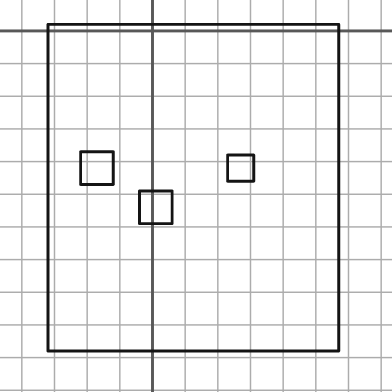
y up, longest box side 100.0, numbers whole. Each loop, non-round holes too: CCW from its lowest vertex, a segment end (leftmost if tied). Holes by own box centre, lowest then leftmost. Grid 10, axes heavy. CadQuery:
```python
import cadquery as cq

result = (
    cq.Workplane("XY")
    .moveTo(-32.0, -98.0)
    .lineTo(57.0, -98.0)
    .lineTo(57.0, 2.0)
    .lineTo(-32.0, 2.0)
    .close()
    .moveTo(-4.0, -59.0)
    .lineTo(6.0, -59.0)
    .lineTo(6.0, -49.0)
    .lineTo(-4.0, -49.0)
    .close()
    .moveTo(-22.0, -47.0)
    .lineTo(-12.0, -47.0)
    .lineTo(-12.0, -37.0)
    .lineTo(-22.0, -37.0)
    .close()
    .moveTo(23.0, -46.0)
    .lineTo(31.0, -46.0)
    .lineTo(31.0, -38.0)
    .lineTo(23.0, -38.0)
    .close()
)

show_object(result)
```